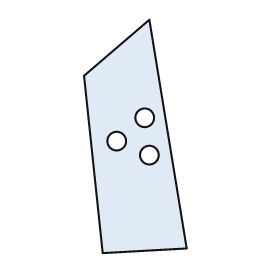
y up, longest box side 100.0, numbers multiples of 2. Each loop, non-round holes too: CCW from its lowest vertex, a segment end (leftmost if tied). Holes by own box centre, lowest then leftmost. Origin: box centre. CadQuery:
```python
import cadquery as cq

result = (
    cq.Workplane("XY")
    .moveTo(-14.0, -50.0)
    .lineTo(22.0, -48.0)
    .lineTo(6.0, 50.0)
    .lineTo(-22.0, 26.0)
    .close()
    .moveTo(6.0, -8.0)
    .circle(4.0)
    .moveTo(-8.0, -2.0)
    .circle(4.0)
    .moveTo(4.0, 8.0)
    .circle(4.0)
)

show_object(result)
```